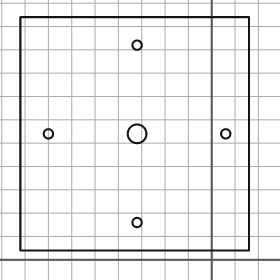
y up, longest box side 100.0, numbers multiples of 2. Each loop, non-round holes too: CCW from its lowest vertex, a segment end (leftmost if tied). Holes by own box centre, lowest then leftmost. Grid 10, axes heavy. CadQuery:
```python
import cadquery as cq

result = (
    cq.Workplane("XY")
    .moveTo(-82.0, 4.0)
    .lineTo(16.0, 4.0)
    .lineTo(16.0, 104.0)
    .lineTo(-82.0, 104.0)
    .close()
    .moveTo(-32.0, 16.0)
    .circle(2.0)
    .moveTo(-70.0, 54.0)
    .circle(2.0)
    .moveTo(-32.0, 54.0)
    .circle(4.0)
    .moveTo(6.0, 54.0)
    .circle(2.0)
    .moveTo(-32.0, 92.0)
    .circle(2.0)
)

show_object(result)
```